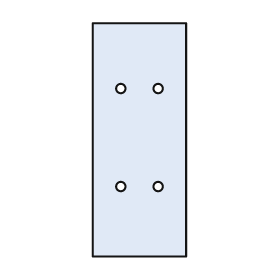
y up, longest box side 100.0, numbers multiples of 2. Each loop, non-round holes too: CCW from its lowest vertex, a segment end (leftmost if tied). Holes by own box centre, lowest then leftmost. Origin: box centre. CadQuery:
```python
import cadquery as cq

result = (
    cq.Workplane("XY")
    .moveTo(-20.0, -50.0)
    .lineTo(20.0, -50.0)
    .lineTo(20.0, 50.0)
    .lineTo(-20.0, 50.0)
    .close()
    .moveTo(-8.0, -20.0)
    .circle(2.0)
    .moveTo(8.0, -20.0)
    .circle(2.0)
    .moveTo(-8.0, 22.0)
    .circle(2.0)
    .moveTo(8.0, 22.0)
    .circle(2.0)
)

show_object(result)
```